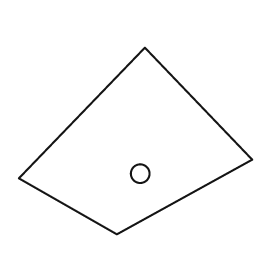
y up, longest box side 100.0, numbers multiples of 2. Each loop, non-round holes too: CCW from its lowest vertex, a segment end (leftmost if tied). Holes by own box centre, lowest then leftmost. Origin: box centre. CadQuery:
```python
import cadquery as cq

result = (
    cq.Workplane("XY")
    .moveTo(-8.0, -40.0)
    .lineTo(50.0, -8.0)
    .lineTo(4.0, 40.0)
    .lineTo(-50.0, -16.0)
    .close()
    .moveTo(2.0, -14.0)
    .circle(4.0)
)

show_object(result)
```